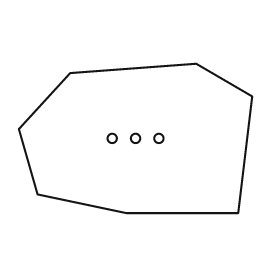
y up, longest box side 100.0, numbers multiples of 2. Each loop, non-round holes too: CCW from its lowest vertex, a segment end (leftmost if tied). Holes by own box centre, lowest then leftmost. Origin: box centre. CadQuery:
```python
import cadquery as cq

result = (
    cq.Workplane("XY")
    .moveTo(-4.0, -32.0)
    .lineTo(44.0, -32.0)
    .lineTo(50.0, 18.0)
    .lineTo(26.0, 32.0)
    .lineTo(-28.0, 28.0)
    .lineTo(-50.0, 4.0)
    .lineTo(-42.0, -24.0)
    .close()
    .moveTo(-10.0, 0.0)
    .circle(2.0)
    .moveTo(0.0, 0.0)
    .circle(2.0)
    .moveTo(10.0, 0.0)
    .circle(2.0)
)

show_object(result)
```